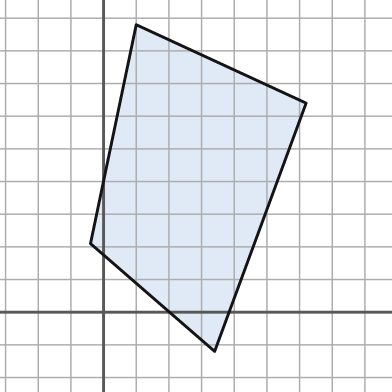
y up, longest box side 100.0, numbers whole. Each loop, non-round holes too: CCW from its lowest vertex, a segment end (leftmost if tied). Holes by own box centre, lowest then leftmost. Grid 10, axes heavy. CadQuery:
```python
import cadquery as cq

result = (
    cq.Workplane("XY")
    .moveTo(34.0, -12.0)
    .lineTo(62.0, 64.0)
    .lineTo(10.0, 88.0)
    .lineTo(-4.0, 21.0)
    .close()
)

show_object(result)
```